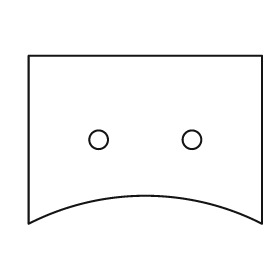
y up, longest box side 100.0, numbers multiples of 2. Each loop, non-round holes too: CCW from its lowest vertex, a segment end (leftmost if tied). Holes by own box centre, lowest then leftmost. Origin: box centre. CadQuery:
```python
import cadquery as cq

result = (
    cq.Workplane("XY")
    .moveTo(-50.0, -36.0)
    .threePointArc((0.0, -24.0), (50.0, -36.0))
    .lineTo(50.0, 36.0)
    .lineTo(-50.0, 36.0)
    .close()
    .moveTo(-20.0, 0.0)
    .circle(4.0)
    .moveTo(20.0, 0.0)
    .circle(4.0)
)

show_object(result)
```